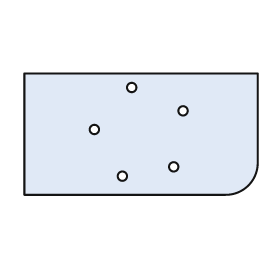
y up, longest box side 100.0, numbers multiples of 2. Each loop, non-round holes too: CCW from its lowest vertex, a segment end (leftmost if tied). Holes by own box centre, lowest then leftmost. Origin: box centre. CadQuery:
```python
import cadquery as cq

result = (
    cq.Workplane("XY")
    .moveTo(-50.0, -26.0)
    .lineTo(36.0, -26.0)
    .threePointArc((46.0, -22.0), (50.0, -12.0))
    .lineTo(50.0, 26.0)
    .lineTo(-50.0, 26.0)
    .close()
    .moveTo(-8.0, -18.0)
    .circle(2.0)
    .moveTo(14.0, -14.0)
    .circle(2.0)
    .moveTo(-20.0, 2.0)
    .circle(2.0)
    .moveTo(18.0, 10.0)
    .circle(2.0)
    .moveTo(-4.0, 20.0)
    .circle(2.0)
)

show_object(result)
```